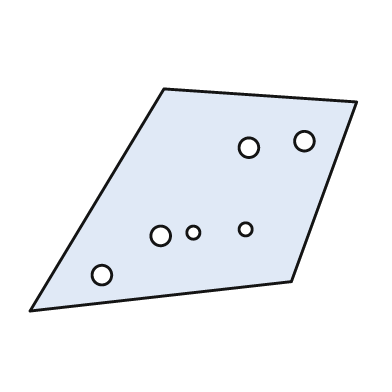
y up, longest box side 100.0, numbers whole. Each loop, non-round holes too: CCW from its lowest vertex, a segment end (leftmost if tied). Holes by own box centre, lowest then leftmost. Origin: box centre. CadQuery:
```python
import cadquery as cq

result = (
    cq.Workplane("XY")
    .moveTo(-50.0, -34.0)
    .lineTo(30.0, -25.0)
    .lineTo(50.0, 30.0)
    .lineTo(-9.0, 34.0)
    .close()
    .moveTo(-28.0, -23.0)
    .circle(3.0)
    .moveTo(-10.0, -11.0)
    .circle(3.0)
    .moveTo(0.0, -10.0)
    .circle(2.0)
    .moveTo(16.0, -9.0)
    .circle(2.0)
    .moveTo(17.0, 16.0)
    .circle(3.0)
    .moveTo(34.0, 18.0)
    .circle(3.0)
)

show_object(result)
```